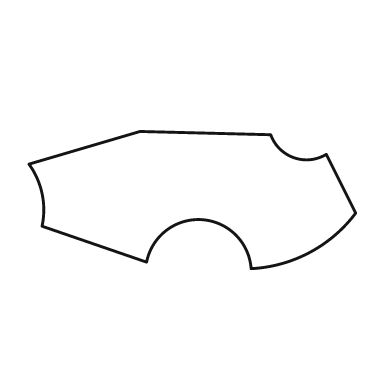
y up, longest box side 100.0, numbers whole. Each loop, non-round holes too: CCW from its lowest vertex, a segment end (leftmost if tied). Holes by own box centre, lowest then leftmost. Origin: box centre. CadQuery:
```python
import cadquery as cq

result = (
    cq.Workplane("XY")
    .moveTo(18.0, -21.0)
    .threePointArc((36.0, -16.0), (50.0, -4.0))
    .lineTo(41.0, 14.0)
    .threePointArc((31.0, 13.0), (24.0, 20.0))
    .lineTo(-16.0, 21.0)
    .lineTo(-50.0, 11.0)
    .threePointArc((-46.0, 2.0), (-46.0, -8.0))
    .lineTo(-14.0, -19.0)
    .threePointArc((3.0, -6.0), (18.0, -21.0))
    .close()
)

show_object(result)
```